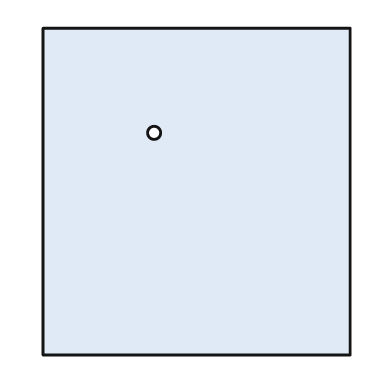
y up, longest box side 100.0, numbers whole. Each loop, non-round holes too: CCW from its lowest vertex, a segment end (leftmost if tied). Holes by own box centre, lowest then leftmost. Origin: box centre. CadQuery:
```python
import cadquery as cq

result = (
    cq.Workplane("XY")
    .moveTo(-47.0, -50.0)
    .lineTo(47.0, -50.0)
    .lineTo(47.0, 50.0)
    .lineTo(-47.0, 50.0)
    .close()
    .moveTo(-13.0, 18.0)
    .circle(2.0)
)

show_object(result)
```